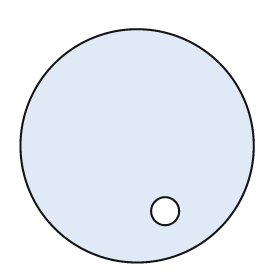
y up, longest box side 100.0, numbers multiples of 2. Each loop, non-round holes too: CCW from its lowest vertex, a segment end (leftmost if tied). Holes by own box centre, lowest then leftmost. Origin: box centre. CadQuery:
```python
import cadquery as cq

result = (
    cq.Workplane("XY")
    .moveTo(0.0, 0.0)
    .circle(50.0)
    .moveTo(12.0, -28.0)
    .circle(6.0)
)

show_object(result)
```